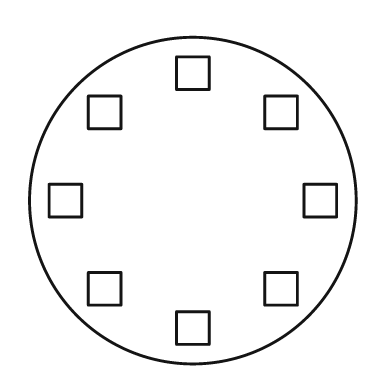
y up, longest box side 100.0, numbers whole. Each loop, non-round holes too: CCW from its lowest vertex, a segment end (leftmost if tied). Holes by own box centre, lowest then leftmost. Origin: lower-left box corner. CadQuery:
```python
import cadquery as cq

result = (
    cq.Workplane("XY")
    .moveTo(50.0, 50.0)
    .circle(50.0)
    .moveTo(45.0, 6.0)
    .lineTo(55.0, 6.0)
    .lineTo(55.0, 16.0)
    .lineTo(45.0, 16.0)
    .close()
    .moveTo(18.0, 18.0)
    .lineTo(28.0, 18.0)
    .lineTo(28.0, 28.0)
    .lineTo(18.0, 28.0)
    .close()
    .moveTo(72.0, 18.0)
    .lineTo(82.0, 18.0)
    .lineTo(82.0, 28.0)
    .lineTo(72.0, 28.0)
    .close()
    .moveTo(6.0, 45.0)
    .lineTo(16.0, 45.0)
    .lineTo(16.0, 55.0)
    .lineTo(6.0, 55.0)
    .close()
    .moveTo(84.0, 45.0)
    .lineTo(94.0, 45.0)
    .lineTo(94.0, 55.0)
    .lineTo(84.0, 55.0)
    .close()
    .moveTo(18.0, 72.0)
    .lineTo(28.0, 72.0)
    .lineTo(28.0, 82.0)
    .lineTo(18.0, 82.0)
    .close()
    .moveTo(72.0, 72.0)
    .lineTo(82.0, 72.0)
    .lineTo(82.0, 82.0)
    .lineTo(72.0, 82.0)
    .close()
    .moveTo(45.0, 84.0)
    .lineTo(55.0, 84.0)
    .lineTo(55.0, 94.0)
    .lineTo(45.0, 94.0)
    .close()
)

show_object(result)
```